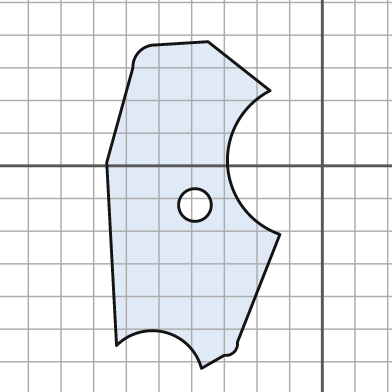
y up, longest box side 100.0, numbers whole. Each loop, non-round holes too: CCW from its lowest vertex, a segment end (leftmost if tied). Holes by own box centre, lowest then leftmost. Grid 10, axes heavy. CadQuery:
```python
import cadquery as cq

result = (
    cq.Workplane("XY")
    .moveTo(-37.0, -62.0)
    .lineTo(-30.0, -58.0)
    .threePointArc((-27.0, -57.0), (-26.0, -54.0))
    .lineTo(-13.0, -21.0)
    .threePointArc((-29.0, 0.0), (-16.0, 23.0))
    .lineTo(-35.0, 38.0)
    .lineTo(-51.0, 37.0)
    .threePointArc((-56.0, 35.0), (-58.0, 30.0))
    .lineTo(-66.0, 1.0)
    .lineTo(-63.0, -55.0)
    .threePointArc((-48.0, -51.0), (-37.0, -62.0))
    .close()
    .moveTo(-39.0, -12.0)
    .circle(5.0)
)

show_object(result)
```